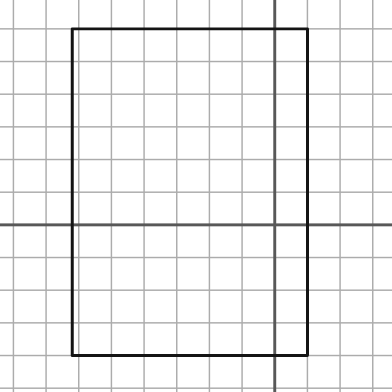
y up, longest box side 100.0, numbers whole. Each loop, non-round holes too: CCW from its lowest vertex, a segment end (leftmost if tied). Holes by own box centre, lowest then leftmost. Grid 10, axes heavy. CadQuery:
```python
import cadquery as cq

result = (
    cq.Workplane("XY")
    .moveTo(-62.0, -40.0)
    .lineTo(10.0, -40.0)
    .lineTo(10.0, 60.0)
    .lineTo(-62.0, 60.0)
    .close()
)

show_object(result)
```